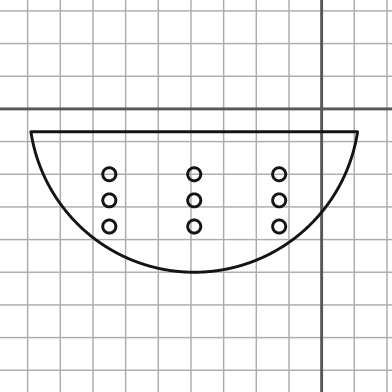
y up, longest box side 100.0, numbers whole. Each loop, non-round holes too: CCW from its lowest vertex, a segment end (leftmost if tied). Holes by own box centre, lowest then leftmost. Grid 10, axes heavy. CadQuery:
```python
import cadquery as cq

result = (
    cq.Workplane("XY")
    .moveTo(-89.0, -7.0)
    .threePointArc((-39.0, -50.0), (11.0, -7.0))
    .close()
    .moveTo(-65.0, -36.0)
    .circle(2.0)
    .moveTo(-39.0, -36.0)
    .circle(2.0)
    .moveTo(-13.0, -36.0)
    .circle(2.0)
    .moveTo(-65.0, -28.0)
    .circle(2.0)
    .moveTo(-39.0, -28.0)
    .circle(2.0)
    .moveTo(-13.0, -28.0)
    .circle(2.0)
    .moveTo(-65.0, -20.0)
    .circle(2.0)
    .moveTo(-39.0, -20.0)
    .circle(2.0)
    .moveTo(-13.0, -20.0)
    .circle(2.0)
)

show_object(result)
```